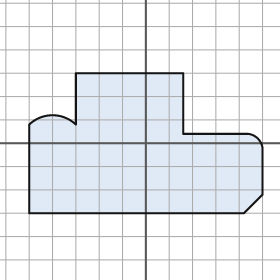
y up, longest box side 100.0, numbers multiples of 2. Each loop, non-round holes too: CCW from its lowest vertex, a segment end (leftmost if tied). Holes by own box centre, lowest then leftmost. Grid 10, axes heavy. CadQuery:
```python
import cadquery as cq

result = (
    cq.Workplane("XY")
    .moveTo(-50.0, -30.0)
    .lineTo(42.0, -30.0)
    .lineTo(50.0, -22.0)
    .lineTo(50.0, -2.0)
    .threePointArc((48.0, 2.0), (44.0, 4.0))
    .lineTo(16.0, 4.0)
    .lineTo(16.0, 30.0)
    .lineTo(-30.0, 30.0)
    .lineTo(-30.0, 8.0)
    .threePointArc((-40.0, 12.0), (-50.0, 8.0))
    .close()
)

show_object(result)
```